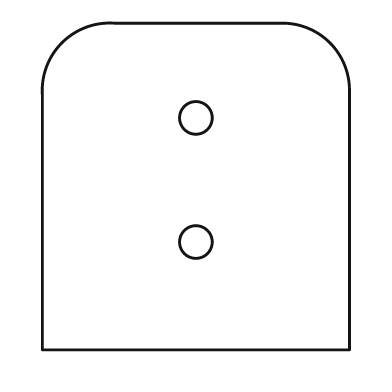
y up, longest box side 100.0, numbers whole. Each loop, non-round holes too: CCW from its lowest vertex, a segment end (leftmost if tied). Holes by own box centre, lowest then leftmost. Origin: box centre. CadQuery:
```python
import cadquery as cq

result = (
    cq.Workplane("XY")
    .moveTo(-47.0, -50.0)
    .lineTo(47.0, -50.0)
    .lineTo(47.0, 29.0)
    .threePointArc((41.0, 44.0), (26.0, 50.0))
    .lineTo(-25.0, 50.0)
    .threePointArc((-41.0, 44.0), (-47.0, 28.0))
    .close()
    .moveTo(0.0, -17.0)
    .circle(5.0)
    .moveTo(0.0, 21.0)
    .circle(5.0)
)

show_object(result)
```